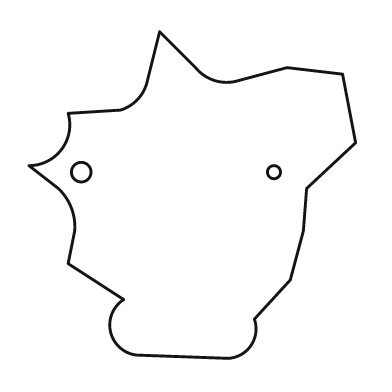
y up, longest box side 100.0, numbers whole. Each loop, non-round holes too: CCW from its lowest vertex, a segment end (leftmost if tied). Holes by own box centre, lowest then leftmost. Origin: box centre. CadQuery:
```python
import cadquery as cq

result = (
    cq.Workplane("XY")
    .moveTo(11.0, -50.0)
    .threePointArc((18.0, -46.0), (19.0, -38.0))
    .lineTo(30.0, -26.0)
    .lineTo(34.0, -11.0)
    .lineTo(35.0, 2.0)
    .lineTo(50.0, 16.0)
    .lineTo(46.0, 37.0)
    .lineTo(29.0, 39.0)
    .lineTo(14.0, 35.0)
    .threePointArc((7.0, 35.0), (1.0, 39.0))
    .lineTo(-10.0, 50.0)
    .lineTo(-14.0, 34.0)
    .threePointArc((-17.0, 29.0), (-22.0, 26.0))
    .lineTo(-38.0, 25.0)
    .threePointArc((-40.0, 14.0), (-50.0, 9.0))
    .lineTo(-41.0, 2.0)
    .threePointArc((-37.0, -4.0), (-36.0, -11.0))
    .lineTo(-38.0, -21.0)
    .lineTo(-21.0, -32.0)
    .threePointArc((-25.0, -42.0), (-17.0, -49.0))
    .close()
    .moveTo(-34.0, 7.0)
    .circle(3.0)
    .moveTo(25.0, 7.0)
    .circle(2.0)
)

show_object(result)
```